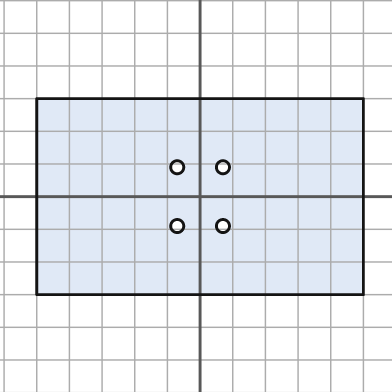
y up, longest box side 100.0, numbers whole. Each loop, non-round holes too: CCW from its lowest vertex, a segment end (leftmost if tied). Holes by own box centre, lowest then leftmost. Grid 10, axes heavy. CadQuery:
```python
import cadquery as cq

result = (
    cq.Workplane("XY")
    .moveTo(-50.0, -30.0)
    .lineTo(50.0, -30.0)
    .lineTo(50.0, 30.0)
    .lineTo(-50.0, 30.0)
    .close()
    .moveTo(-7.0, -9.0)
    .circle(2.0)
    .moveTo(7.0, -9.0)
    .circle(2.0)
    .moveTo(-7.0, 9.0)
    .circle(2.0)
    .moveTo(7.0, 9.0)
    .circle(2.0)
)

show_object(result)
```